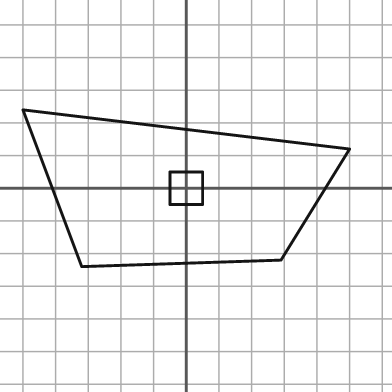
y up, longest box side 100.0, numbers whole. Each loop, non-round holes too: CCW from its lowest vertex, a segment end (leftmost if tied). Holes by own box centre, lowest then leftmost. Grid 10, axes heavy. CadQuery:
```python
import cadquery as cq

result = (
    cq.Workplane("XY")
    .moveTo(-32.0, -24.0)
    .lineTo(29.0, -22.0)
    .lineTo(50.0, 12.0)
    .lineTo(-50.0, 24.0)
    .close()
    .moveTo(-5.0, -5.0)
    .lineTo(5.0, -5.0)
    .lineTo(5.0, 5.0)
    .lineTo(-5.0, 5.0)
    .close()
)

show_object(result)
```